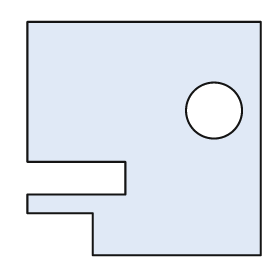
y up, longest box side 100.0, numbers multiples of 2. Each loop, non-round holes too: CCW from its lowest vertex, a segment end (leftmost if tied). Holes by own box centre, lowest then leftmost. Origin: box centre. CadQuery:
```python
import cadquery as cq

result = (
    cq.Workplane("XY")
    .moveTo(-22.0, -50.0)
    .lineTo(50.0, -50.0)
    .lineTo(50.0, 50.0)
    .lineTo(-50.0, 50.0)
    .lineTo(-50.0, -10.0)
    .lineTo(-8.0, -10.0)
    .lineTo(-8.0, -24.0)
    .lineTo(-50.0, -24.0)
    .lineTo(-50.0, -32.0)
    .lineTo(-22.0, -32.0)
    .close()
    .moveTo(30.0, 12.0)
    .circle(12.0)
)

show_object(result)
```